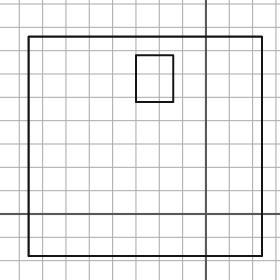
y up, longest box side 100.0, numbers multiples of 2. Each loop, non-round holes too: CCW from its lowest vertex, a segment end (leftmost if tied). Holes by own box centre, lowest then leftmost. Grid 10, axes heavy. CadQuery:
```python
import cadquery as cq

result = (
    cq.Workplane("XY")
    .moveTo(-76.0, -18.0)
    .lineTo(24.0, -18.0)
    .lineTo(24.0, 76.0)
    .lineTo(-76.0, 76.0)
    .close()
    .moveTo(-30.0, 48.0)
    .lineTo(-14.0, 48.0)
    .lineTo(-14.0, 68.0)
    .lineTo(-30.0, 68.0)
    .close()
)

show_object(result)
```